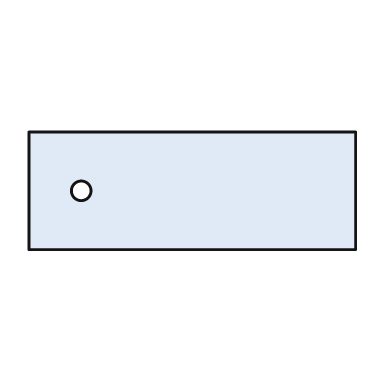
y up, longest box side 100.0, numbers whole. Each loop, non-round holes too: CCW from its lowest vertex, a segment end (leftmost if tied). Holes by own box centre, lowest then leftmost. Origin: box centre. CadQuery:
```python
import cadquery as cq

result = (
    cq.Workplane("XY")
    .moveTo(-50.0, -18.0)
    .lineTo(50.0, -18.0)
    .lineTo(50.0, 18.0)
    .lineTo(-50.0, 18.0)
    .close()
    .moveTo(-34.0, 0.0)
    .circle(3.0)
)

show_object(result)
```